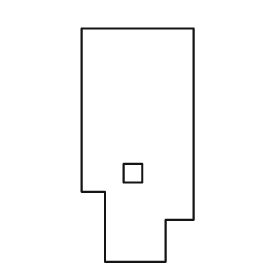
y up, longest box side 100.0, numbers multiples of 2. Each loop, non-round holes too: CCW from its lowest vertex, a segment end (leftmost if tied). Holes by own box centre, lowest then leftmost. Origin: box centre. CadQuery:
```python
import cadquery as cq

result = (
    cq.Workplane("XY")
    .moveTo(-14.0, -50.0)
    .lineTo(12.0, -50.0)
    .lineTo(12.0, -32.0)
    .lineTo(24.0, -32.0)
    .lineTo(24.0, 50.0)
    .lineTo(-24.0, 50.0)
    .lineTo(-24.0, -20.0)
    .lineTo(-14.0, -20.0)
    .close()
    .moveTo(-6.0, -16.0)
    .lineTo(2.0, -16.0)
    .lineTo(2.0, -8.0)
    .lineTo(-6.0, -8.0)
    .close()
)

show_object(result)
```